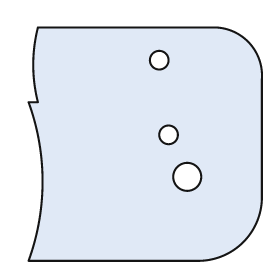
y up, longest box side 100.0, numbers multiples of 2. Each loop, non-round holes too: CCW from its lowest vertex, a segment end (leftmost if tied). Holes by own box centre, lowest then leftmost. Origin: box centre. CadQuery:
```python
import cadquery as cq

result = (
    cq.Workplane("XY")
    .moveTo(-50.0, -50.0)
    .lineTo(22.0, -50.0)
    .threePointArc((42.0, -42.0), (50.0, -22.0))
    .lineTo(50.0, 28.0)
    .threePointArc((44.0, 44.0), (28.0, 50.0))
    .lineTo(-46.0, 50.0)
    .threePointArc((-48.0, 34.0), (-46.0, 18.0))
    .lineTo(-50.0, 18.0)
    .threePointArc((-44.0, -16.0), (-50.0, -50.0))
    .close()
    .moveTo(18.0, -14.0)
    .circle(6.0)
    .moveTo(10.0, 4.0)
    .circle(4.0)
    .moveTo(6.0, 36.0)
    .circle(4.0)
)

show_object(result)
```